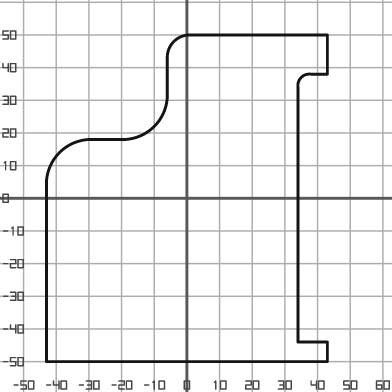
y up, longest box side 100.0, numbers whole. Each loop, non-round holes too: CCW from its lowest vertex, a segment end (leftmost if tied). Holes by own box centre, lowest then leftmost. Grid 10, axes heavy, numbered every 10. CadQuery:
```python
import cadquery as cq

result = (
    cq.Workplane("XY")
    .moveTo(-43.0, -50.0)
    .lineTo(43.0, -50.0)
    .lineTo(43.0, -44.0)
    .lineTo(34.0, -44.0)
    .lineTo(34.0, 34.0)
    .threePointArc((35.0, 37.0), (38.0, 38.0))
    .lineTo(43.0, 38.0)
    .lineTo(43.0, 50.0)
    .lineTo(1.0, 50.0)
    .threePointArc((-4.0, 48.0), (-6.0, 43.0))
    .lineTo(-6.0, 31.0)
    .threePointArc((-10.0, 22.0), (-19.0, 18.0))
    .lineTo(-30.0, 18.0)
    .threePointArc((-39.0, 14.0), (-43.0, 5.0))
    .close()
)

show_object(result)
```